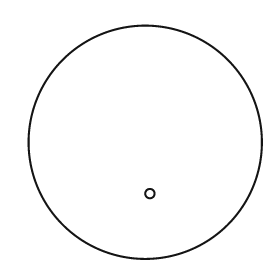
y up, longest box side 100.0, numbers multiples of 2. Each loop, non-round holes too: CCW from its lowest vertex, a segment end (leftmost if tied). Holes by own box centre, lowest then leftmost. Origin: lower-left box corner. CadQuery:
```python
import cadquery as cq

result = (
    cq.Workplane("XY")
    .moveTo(50.0, 50.0)
    .circle(50.0)
    .moveTo(52.0, 28.0)
    .circle(2.0)
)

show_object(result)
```